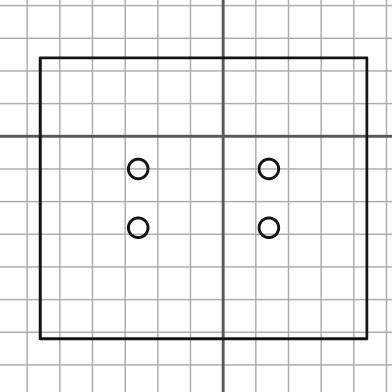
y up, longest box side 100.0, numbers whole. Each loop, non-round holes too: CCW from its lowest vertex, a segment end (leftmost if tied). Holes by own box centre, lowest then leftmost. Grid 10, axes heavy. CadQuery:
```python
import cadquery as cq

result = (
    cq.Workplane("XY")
    .moveTo(-56.0, -62.0)
    .lineTo(44.0, -62.0)
    .lineTo(44.0, 24.0)
    .lineTo(-56.0, 24.0)
    .close()
    .moveTo(-26.0, -28.0)
    .circle(3.0)
    .moveTo(14.0, -28.0)
    .circle(3.0)
    .moveTo(-26.0, -10.0)
    .circle(3.0)
    .moveTo(14.0, -10.0)
    .circle(3.0)
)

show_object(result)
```